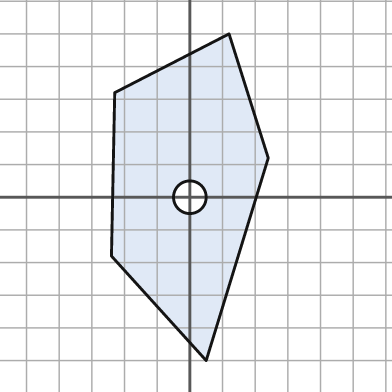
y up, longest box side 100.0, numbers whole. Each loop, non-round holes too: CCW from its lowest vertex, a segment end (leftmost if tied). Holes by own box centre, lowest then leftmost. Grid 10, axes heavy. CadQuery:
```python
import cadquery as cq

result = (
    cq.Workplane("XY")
    .moveTo(5.0, -50.0)
    .lineTo(24.0, 12.0)
    .lineTo(12.0, 50.0)
    .lineTo(-23.0, 32.0)
    .lineTo(-24.0, -18.0)
    .close()
    .moveTo(0.0, 0.0)
    .circle(5.0)
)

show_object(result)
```